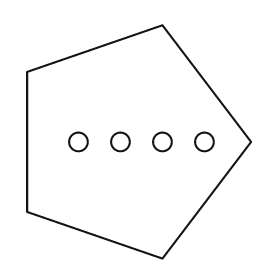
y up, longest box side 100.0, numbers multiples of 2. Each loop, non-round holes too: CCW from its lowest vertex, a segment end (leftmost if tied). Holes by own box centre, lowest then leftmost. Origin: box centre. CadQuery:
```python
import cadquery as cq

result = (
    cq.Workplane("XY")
    .moveTo(10.0, -50.0)
    .lineTo(48.0, 0.0)
    .lineTo(10.0, 50.0)
    .lineTo(-48.0, 30.0)
    .lineTo(-48.0, -30.0)
    .close()
    .moveTo(-26.0, 0.0)
    .circle(4.0)
    .moveTo(-8.0, 0.0)
    .circle(4.0)
    .moveTo(10.0, 0.0)
    .circle(4.0)
    .moveTo(28.0, 0.0)
    .circle(4.0)
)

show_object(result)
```